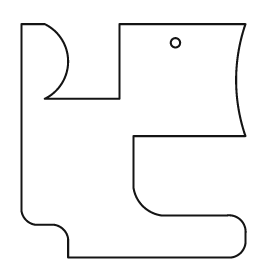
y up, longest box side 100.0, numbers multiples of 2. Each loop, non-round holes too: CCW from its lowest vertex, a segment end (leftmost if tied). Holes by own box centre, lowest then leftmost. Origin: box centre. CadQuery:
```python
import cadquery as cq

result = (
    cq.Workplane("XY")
    .moveTo(-28.0, -50.0)
    .lineTo(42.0, -50.0)
    .threePointArc((46.0, -48.0), (48.0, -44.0))
    .lineTo(48.0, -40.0)
    .threePointArc((46.0, -34.0), (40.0, -32.0))
    .lineTo(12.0, -32.0)
    .threePointArc((4.0, -28.0), (0.0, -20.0))
    .lineTo(0.0, 2.0)
    .lineTo(48.0, 2.0)
    .threePointArc((44.0, 26.0), (48.0, 50.0))
    .lineTo(-6.0, 50.0)
    .lineTo(-6.0, 18.0)
    .lineTo(-38.0, 18.0)
    .threePointArc((-28.0, 34.0), (-38.0, 50.0))
    .lineTo(-48.0, 50.0)
    .lineTo(-48.0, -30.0)
    .threePointArc((-46.0, -34.0), (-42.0, -36.0))
    .lineTo(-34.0, -36.0)
    .threePointArc((-30.0, -38.0), (-28.0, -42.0))
    .close()
    .moveTo(18.0, 42.0)
    .circle(2.0)
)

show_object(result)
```